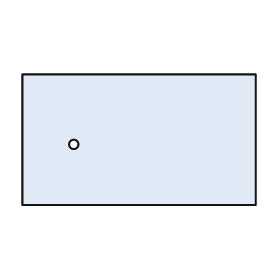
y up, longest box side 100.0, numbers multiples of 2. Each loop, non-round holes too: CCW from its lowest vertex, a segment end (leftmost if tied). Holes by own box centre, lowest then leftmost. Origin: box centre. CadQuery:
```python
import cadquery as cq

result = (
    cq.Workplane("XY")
    .moveTo(-50.0, -28.0)
    .lineTo(50.0, -28.0)
    .lineTo(50.0, 28.0)
    .lineTo(-50.0, 28.0)
    .close()
    .moveTo(-28.0, -2.0)
    .circle(2.0)
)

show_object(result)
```